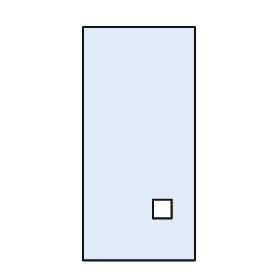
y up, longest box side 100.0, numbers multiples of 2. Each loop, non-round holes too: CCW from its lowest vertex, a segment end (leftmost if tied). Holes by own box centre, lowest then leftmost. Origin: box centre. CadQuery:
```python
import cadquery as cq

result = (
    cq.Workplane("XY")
    .moveTo(-24.0, -50.0)
    .lineTo(24.0, -50.0)
    .lineTo(24.0, 50.0)
    .lineTo(-24.0, 50.0)
    .close()
    .moveTo(6.0, -32.0)
    .lineTo(14.0, -32.0)
    .lineTo(14.0, -24.0)
    .lineTo(6.0, -24.0)
    .close()
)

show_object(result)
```